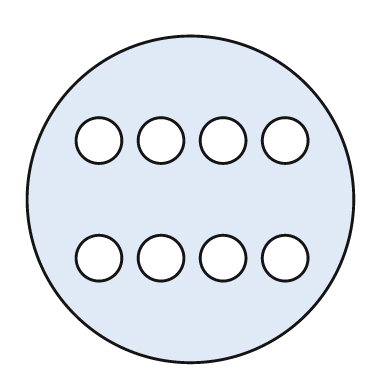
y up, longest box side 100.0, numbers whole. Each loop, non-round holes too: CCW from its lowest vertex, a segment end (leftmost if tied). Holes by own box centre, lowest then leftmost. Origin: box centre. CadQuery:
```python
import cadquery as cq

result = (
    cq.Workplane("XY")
    .moveTo(0.0, 0.0)
    .circle(50.0)
    .moveTo(-28.0, -18.0)
    .circle(7.0)
    .moveTo(-9.0, -18.0)
    .circle(7.0)
    .moveTo(10.0, -18.0)
    .circle(7.0)
    .moveTo(29.0, -18.0)
    .circle(7.0)
    .moveTo(-28.0, 18.0)
    .circle(7.0)
    .moveTo(-9.0, 18.0)
    .circle(7.0)
    .moveTo(10.0, 18.0)
    .circle(7.0)
    .moveTo(29.0, 18.0)
    .circle(7.0)
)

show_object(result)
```